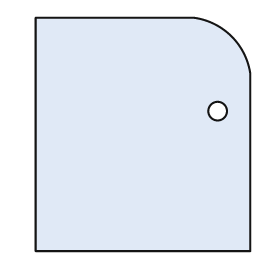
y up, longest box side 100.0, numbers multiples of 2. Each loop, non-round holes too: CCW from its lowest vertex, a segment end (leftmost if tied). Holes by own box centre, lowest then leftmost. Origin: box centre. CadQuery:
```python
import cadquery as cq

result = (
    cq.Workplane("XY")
    .moveTo(-46.0, -50.0)
    .lineTo(46.0, -50.0)
    .lineTo(46.0, 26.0)
    .threePointArc((38.0, 42.0), (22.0, 50.0))
    .lineTo(-46.0, 50.0)
    .close()
    .moveTo(32.0, 10.0)
    .circle(4.0)
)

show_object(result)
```